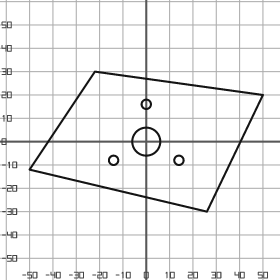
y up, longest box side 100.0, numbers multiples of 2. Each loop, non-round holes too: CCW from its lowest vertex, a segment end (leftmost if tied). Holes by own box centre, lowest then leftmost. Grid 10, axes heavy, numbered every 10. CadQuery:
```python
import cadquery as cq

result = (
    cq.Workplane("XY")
    .moveTo(26.0, -30.0)
    .lineTo(50.0, 20.0)
    .lineTo(-22.0, 30.0)
    .lineTo(-50.0, -12.0)
    .close()
    .moveTo(-14.0, -8.0)
    .circle(2.0)
    .moveTo(14.0, -8.0)
    .circle(2.0)
    .moveTo(0.0, 0.0)
    .circle(6.0)
    .moveTo(0.0, 16.0)
    .circle(2.0)
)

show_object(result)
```